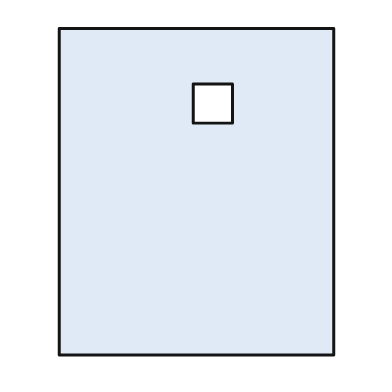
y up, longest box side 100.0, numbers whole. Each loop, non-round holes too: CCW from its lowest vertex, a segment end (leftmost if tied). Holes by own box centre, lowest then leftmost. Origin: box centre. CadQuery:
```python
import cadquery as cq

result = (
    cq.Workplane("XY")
    .moveTo(-42.0, -50.0)
    .lineTo(42.0, -50.0)
    .lineTo(42.0, 50.0)
    .lineTo(-42.0, 50.0)
    .close()
    .moveTo(-1.0, 21.0)
    .lineTo(11.0, 21.0)
    .lineTo(11.0, 33.0)
    .lineTo(-1.0, 33.0)
    .close()
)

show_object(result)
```